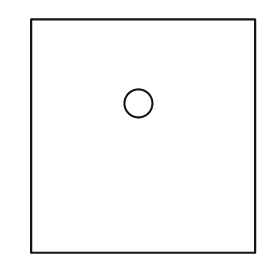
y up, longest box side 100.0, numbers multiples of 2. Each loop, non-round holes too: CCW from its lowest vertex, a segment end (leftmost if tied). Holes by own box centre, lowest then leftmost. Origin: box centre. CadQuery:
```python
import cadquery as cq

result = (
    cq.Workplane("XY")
    .moveTo(-48.0, -50.0)
    .lineTo(48.0, -50.0)
    .lineTo(48.0, 50.0)
    .lineTo(-48.0, 50.0)
    .close()
    .moveTo(-2.0, 14.0)
    .circle(6.0)
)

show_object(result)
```